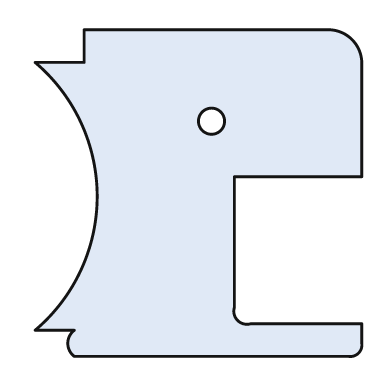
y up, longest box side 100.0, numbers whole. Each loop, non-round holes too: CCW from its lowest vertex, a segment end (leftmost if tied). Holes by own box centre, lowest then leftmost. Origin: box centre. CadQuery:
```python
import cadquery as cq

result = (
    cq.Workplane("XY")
    .moveTo(-38.0, -50.0)
    .lineTo(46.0, -50.0)
    .threePointArc((49.0, -49.0), (50.0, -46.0))
    .lineTo(50.0, -40.0)
    .lineTo(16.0, -40.0)
    .threePointArc((12.0, -39.0), (11.0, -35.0))
    .lineTo(11.0, 5.0)
    .lineTo(50.0, 5.0)
    .lineTo(50.0, 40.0)
    .threePointArc((47.0, 47.0), (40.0, 50.0))
    .lineTo(-35.0, 50.0)
    .lineTo(-35.0, 40.0)
    .lineTo(-50.0, 40.0)
    .threePointArc((-31.0, -1.0), (-50.0, -42.0))
    .lineTo(-38.0, -42.0)
    .threePointArc((-40.0, -46.0), (-38.0, -50.0))
    .close()
    .moveTo(4.0, 22.0)
    .circle(4.0)
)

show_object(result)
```